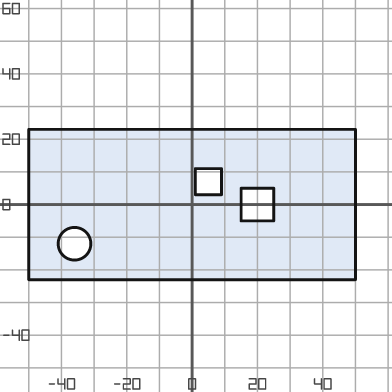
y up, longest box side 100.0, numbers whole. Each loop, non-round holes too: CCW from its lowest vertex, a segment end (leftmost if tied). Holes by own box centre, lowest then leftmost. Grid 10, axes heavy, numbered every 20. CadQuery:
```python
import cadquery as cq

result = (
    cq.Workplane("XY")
    .moveTo(-50.0, -23.0)
    .lineTo(50.0, -23.0)
    .lineTo(50.0, 23.0)
    .lineTo(-50.0, 23.0)
    .close()
    .moveTo(-36.0, -12.0)
    .circle(5.0)
    .moveTo(15.0, -5.0)
    .lineTo(25.0, -5.0)
    .lineTo(25.0, 5.0)
    .lineTo(15.0, 5.0)
    .close()
    .moveTo(1.0, 3.0)
    .lineTo(9.0, 3.0)
    .lineTo(9.0, 11.0)
    .lineTo(1.0, 11.0)
    .close()
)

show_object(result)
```